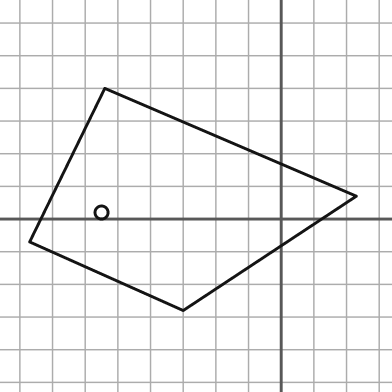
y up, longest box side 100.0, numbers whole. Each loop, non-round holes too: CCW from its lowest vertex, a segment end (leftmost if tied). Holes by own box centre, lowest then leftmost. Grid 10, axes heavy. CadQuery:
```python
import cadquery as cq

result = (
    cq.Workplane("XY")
    .moveTo(-30.0, -28.0)
    .lineTo(23.0, 7.0)
    .lineTo(-54.0, 40.0)
    .lineTo(-77.0, -7.0)
    .close()
    .moveTo(-55.0, 2.0)
    .circle(2.0)
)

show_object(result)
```